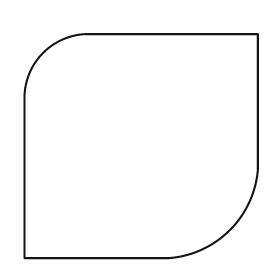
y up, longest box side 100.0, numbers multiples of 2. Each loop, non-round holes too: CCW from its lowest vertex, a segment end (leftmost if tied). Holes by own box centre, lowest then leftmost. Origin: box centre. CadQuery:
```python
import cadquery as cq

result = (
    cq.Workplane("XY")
    .moveTo(-50.0, -48.0)
    .lineTo(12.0, -48.0)
    .threePointArc((38.0, -36.0), (50.0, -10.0))
    .lineTo(50.0, 48.0)
    .lineTo(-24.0, 48.0)
    .threePointArc((-42.0, 40.0), (-50.0, 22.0))
    .close()
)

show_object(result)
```